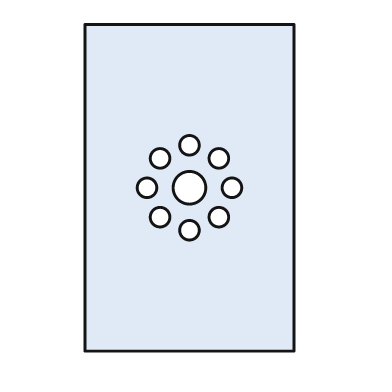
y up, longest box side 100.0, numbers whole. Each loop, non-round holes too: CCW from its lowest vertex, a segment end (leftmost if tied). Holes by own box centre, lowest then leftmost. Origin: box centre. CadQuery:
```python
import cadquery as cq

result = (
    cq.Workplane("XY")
    .moveTo(-32.0, -50.0)
    .lineTo(32.0, -50.0)
    .lineTo(32.0, 50.0)
    .lineTo(-32.0, 50.0)
    .close()
    .moveTo(0.0, -13.0)
    .circle(3.0)
    .moveTo(-9.0, -9.0)
    .circle(3.0)
    .moveTo(9.0, -9.0)
    .circle(3.0)
    .moveTo(-13.0, 0.0)
    .circle(3.0)
    .moveTo(0.0, 0.0)
    .circle(5.0)
    .moveTo(13.0, 0.0)
    .circle(3.0)
    .moveTo(-9.0, 9.0)
    .circle(3.0)
    .moveTo(9.0, 9.0)
    .circle(3.0)
    .moveTo(0.0, 13.0)
    .circle(3.0)
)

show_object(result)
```